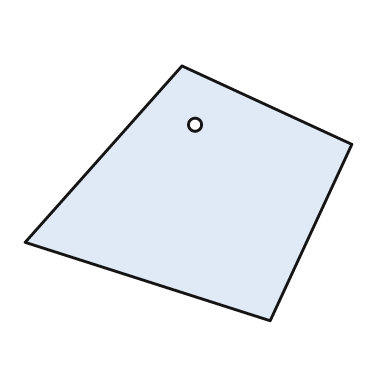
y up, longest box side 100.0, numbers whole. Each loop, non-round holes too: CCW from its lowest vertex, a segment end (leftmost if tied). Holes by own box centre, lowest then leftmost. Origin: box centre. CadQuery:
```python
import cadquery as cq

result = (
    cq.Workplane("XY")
    .moveTo(25.0, -39.0)
    .lineTo(50.0, 15.0)
    .lineTo(-2.0, 39.0)
    .lineTo(-50.0, -15.0)
    .close()
    .moveTo(2.0, 21.0)
    .circle(2.0)
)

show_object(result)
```